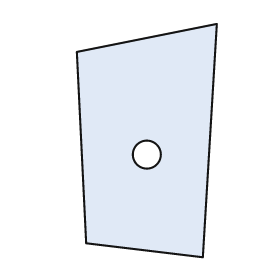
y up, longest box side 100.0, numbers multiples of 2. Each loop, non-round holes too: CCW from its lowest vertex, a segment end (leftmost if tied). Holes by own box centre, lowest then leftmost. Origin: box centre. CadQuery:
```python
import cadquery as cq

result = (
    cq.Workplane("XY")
    .moveTo(24.0, -50.0)
    .lineTo(30.0, 50.0)
    .lineTo(-30.0, 38.0)
    .lineTo(-26.0, -44.0)
    .close()
    .moveTo(0.0, -6.0)
    .circle(6.0)
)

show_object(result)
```